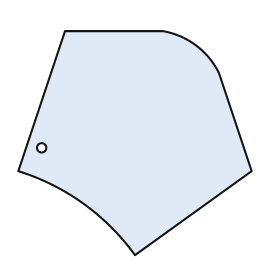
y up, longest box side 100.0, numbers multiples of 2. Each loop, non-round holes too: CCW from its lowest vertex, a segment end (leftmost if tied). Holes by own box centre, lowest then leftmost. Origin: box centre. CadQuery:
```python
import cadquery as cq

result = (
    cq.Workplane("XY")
    .moveTo(0.0, -48.0)
    .lineTo(50.0, -12.0)
    .lineTo(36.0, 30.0)
    .threePointArc((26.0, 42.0), (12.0, 48.0))
    .lineTo(-30.0, 48.0)
    .lineTo(-50.0, -12.0)
    .threePointArc((-22.0, -26.0), (0.0, -48.0))
    .close()
    .moveTo(-40.0, -2.0)
    .circle(2.0)
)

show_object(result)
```